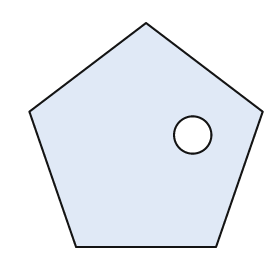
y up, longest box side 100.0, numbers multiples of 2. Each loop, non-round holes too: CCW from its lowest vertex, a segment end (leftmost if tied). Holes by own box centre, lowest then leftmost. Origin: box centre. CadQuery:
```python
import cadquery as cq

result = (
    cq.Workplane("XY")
    .moveTo(-30.0, -48.0)
    .lineTo(30.0, -48.0)
    .lineTo(50.0, 10.0)
    .lineTo(0.0, 48.0)
    .lineTo(-50.0, 10.0)
    .close()
    .moveTo(20.0, 0.0)
    .circle(8.0)
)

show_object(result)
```